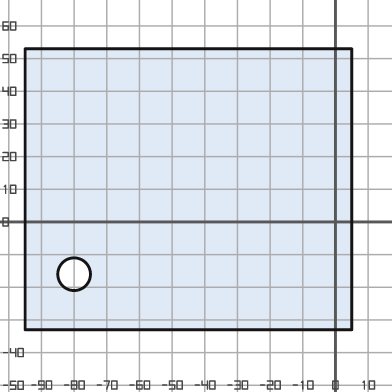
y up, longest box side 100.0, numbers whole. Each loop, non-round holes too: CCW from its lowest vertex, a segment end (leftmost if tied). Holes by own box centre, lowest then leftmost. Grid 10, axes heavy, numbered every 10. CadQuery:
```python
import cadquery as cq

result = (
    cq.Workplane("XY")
    .moveTo(-95.0, -33.0)
    .lineTo(5.0, -33.0)
    .lineTo(5.0, 53.0)
    .lineTo(-95.0, 53.0)
    .close()
    .moveTo(-80.0, -16.0)
    .circle(5.0)
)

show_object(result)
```